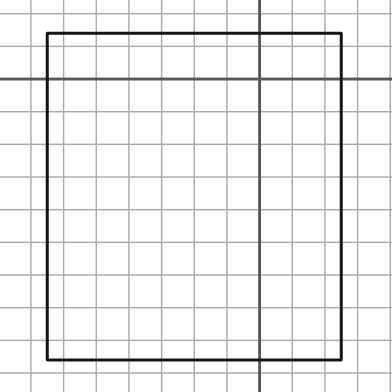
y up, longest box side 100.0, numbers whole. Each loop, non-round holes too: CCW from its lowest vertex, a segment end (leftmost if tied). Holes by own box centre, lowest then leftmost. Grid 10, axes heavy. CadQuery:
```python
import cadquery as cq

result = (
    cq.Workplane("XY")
    .moveTo(-65.0, -86.0)
    .lineTo(25.0, -86.0)
    .lineTo(25.0, 14.0)
    .lineTo(-65.0, 14.0)
    .close()
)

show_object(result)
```